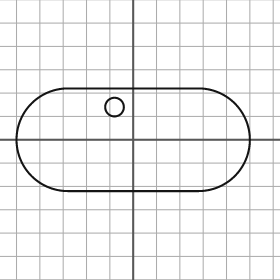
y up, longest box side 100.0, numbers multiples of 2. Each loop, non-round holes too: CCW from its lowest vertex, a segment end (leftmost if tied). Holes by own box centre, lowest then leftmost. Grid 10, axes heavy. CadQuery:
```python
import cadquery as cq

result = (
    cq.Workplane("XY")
    .moveTo(-28.0, -22.0)
    .lineTo(28.0, -22.0)
    .threePointArc((50.0, 0.0), (28.0, 22.0))
    .lineTo(-28.0, 22.0)
    .threePointArc((-50.0, 0.0), (-28.0, -22.0))
    .close()
    .moveTo(-8.0, 14.0)
    .circle(4.0)
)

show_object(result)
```